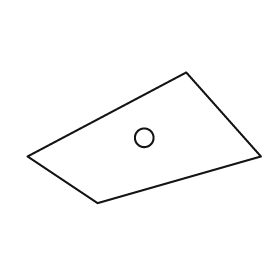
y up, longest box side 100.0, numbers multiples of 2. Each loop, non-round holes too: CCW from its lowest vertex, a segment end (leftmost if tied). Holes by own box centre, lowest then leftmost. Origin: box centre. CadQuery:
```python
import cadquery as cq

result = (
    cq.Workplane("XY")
    .moveTo(-20.0, -28.0)
    .lineTo(50.0, -8.0)
    .lineTo(18.0, 28.0)
    .lineTo(-50.0, -8.0)
    .close()
    .moveTo(0.0, 0.0)
    .circle(4.0)
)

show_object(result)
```